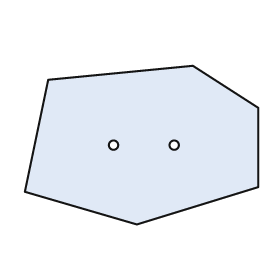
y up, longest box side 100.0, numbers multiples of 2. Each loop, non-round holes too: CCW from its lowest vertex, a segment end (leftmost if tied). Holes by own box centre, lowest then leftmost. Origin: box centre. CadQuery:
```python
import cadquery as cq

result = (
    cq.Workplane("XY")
    .moveTo(-2.0, -34.0)
    .lineTo(50.0, -18.0)
    .lineTo(50.0, 16.0)
    .lineTo(22.0, 34.0)
    .lineTo(-40.0, 28.0)
    .lineTo(-50.0, -20.0)
    .close()
    .moveTo(-12.0, 0.0)
    .circle(2.0)
    .moveTo(14.0, 0.0)
    .circle(2.0)
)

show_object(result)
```